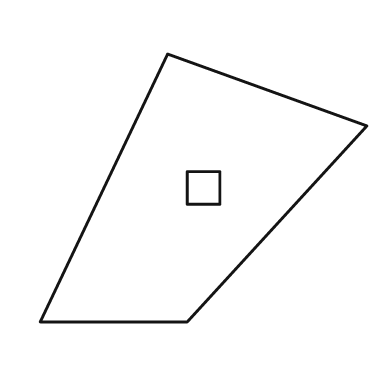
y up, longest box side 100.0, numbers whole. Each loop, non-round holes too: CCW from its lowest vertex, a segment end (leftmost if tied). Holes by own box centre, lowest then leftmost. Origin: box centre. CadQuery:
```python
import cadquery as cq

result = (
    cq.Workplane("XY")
    .moveTo(-50.0, -41.0)
    .lineTo(-5.0, -41.0)
    .lineTo(50.0, 19.0)
    .lineTo(-11.0, 41.0)
    .close()
    .moveTo(-5.0, -5.0)
    .lineTo(5.0, -5.0)
    .lineTo(5.0, 5.0)
    .lineTo(-5.0, 5.0)
    .close()
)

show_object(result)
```